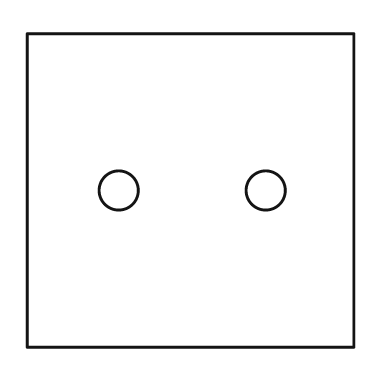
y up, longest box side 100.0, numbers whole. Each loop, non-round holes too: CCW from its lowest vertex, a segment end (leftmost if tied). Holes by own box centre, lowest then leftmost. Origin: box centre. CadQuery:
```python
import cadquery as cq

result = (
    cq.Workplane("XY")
    .moveTo(-50.0, -48.0)
    .lineTo(50.0, -48.0)
    .lineTo(50.0, 48.0)
    .lineTo(-50.0, 48.0)
    .close()
    .moveTo(-22.0, 0.0)
    .circle(6.0)
    .moveTo(23.0, 0.0)
    .circle(6.0)
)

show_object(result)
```